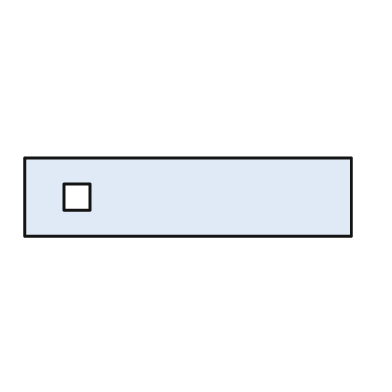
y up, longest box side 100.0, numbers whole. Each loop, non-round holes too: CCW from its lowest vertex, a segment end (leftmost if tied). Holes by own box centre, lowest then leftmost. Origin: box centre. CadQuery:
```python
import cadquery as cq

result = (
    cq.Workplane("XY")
    .moveTo(-50.0, -12.0)
    .lineTo(50.0, -12.0)
    .lineTo(50.0, 12.0)
    .lineTo(-50.0, 12.0)
    .close()
    .moveTo(-38.0, -4.0)
    .lineTo(-30.0, -4.0)
    .lineTo(-30.0, 4.0)
    .lineTo(-38.0, 4.0)
    .close()
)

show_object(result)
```